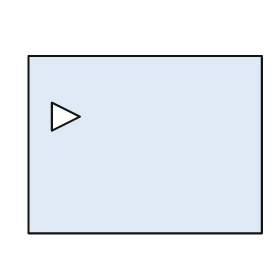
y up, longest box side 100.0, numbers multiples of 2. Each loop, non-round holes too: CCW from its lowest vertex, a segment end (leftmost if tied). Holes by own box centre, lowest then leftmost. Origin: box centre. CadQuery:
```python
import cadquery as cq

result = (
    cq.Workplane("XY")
    .moveTo(-50.0, -38.0)
    .lineTo(50.0, -38.0)
    .lineTo(50.0, 38.0)
    .lineTo(-50.0, 38.0)
    .close()
    .moveTo(-40.0, 6.0)
    .lineTo(-28.0, 12.0)
    .lineTo(-40.0, 18.0)
    .close()
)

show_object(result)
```